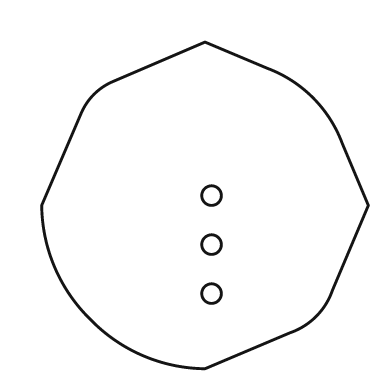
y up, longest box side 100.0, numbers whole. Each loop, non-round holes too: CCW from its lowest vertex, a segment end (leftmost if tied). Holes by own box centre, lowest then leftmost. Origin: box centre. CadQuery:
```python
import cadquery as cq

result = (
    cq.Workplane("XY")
    .moveTo(0.0, -50.0)
    .lineTo(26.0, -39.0)
    .threePointArc((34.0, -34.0), (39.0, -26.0))
    .lineTo(50.0, 0.0)
    .lineTo(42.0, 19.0)
    .threePointArc((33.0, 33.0), (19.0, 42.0))
    .lineTo(0.0, 50.0)
    .lineTo(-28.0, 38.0)
    .threePointArc((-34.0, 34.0), (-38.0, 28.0))
    .lineTo(-50.0, 0.0)
    .threePointArc((-46.0, -19.0), (-35.0, -35.0))
    .threePointArc((-19.0, -46.0), (0.0, -50.0))
    .close()
    .moveTo(2.0, -27.0)
    .circle(3.0)
    .moveTo(2.0, -12.0)
    .circle(3.0)
    .moveTo(2.0, 3.0)
    .circle(3.0)
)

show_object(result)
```